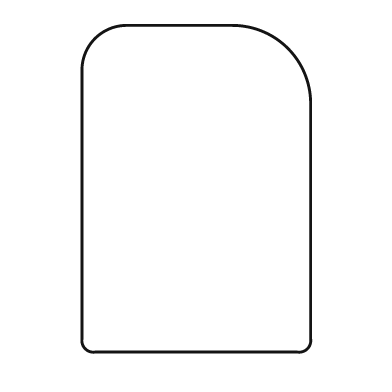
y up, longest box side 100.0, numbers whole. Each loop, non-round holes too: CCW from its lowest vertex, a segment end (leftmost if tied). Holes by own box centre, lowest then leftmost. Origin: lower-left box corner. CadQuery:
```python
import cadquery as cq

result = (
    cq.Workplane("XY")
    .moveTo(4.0, 0.0)
    .lineTo(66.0, 0.0)
    .threePointArc((69.0, 1.0), (70.0, 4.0))
    .lineTo(70.0, 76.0)
    .threePointArc((63.0, 93.0), (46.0, 100.0))
    .lineTo(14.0, 100.0)
    .threePointArc((4.0, 96.0), (0.0, 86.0))
    .lineTo(0.0, 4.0)
    .threePointArc((1.0, 1.0), (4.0, 0.0))
    .close()
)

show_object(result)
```